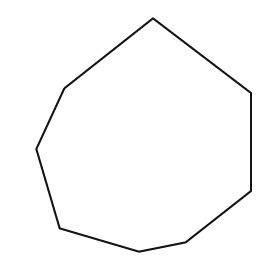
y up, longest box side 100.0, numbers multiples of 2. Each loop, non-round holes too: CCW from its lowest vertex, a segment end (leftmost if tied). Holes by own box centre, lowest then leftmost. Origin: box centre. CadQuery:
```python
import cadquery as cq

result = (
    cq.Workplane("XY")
    .moveTo(-2.0, -50.0)
    .lineTo(18.0, -46.0)
    .lineTo(46.0, -24.0)
    .lineTo(46.0, 18.0)
    .lineTo(4.0, 50.0)
    .lineTo(-34.0, 20.0)
    .lineTo(-46.0, -6.0)
    .lineTo(-36.0, -40.0)
    .close()
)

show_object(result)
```